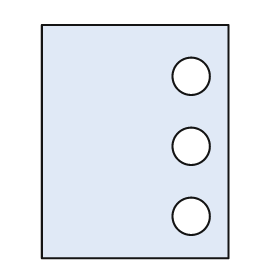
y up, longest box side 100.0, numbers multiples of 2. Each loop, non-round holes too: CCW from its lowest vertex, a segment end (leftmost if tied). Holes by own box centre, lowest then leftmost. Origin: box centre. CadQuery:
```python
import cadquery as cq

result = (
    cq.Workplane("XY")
    .moveTo(-40.0, -50.0)
    .lineTo(40.0, -50.0)
    .lineTo(40.0, 50.0)
    .lineTo(-40.0, 50.0)
    .close()
    .moveTo(24.0, -32.0)
    .circle(8.0)
    .moveTo(24.0, -2.0)
    .circle(8.0)
    .moveTo(24.0, 28.0)
    .circle(8.0)
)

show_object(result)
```